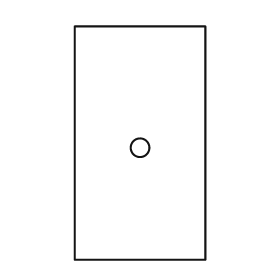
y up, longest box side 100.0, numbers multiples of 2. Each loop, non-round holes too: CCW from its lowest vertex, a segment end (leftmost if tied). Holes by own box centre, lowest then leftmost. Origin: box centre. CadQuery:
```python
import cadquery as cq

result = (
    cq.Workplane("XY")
    .moveTo(-28.0, -50.0)
    .lineTo(28.0, -50.0)
    .lineTo(28.0, 50.0)
    .lineTo(-28.0, 50.0)
    .close()
    .moveTo(0.0, -2.0)
    .circle(4.0)
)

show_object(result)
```